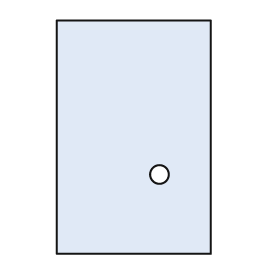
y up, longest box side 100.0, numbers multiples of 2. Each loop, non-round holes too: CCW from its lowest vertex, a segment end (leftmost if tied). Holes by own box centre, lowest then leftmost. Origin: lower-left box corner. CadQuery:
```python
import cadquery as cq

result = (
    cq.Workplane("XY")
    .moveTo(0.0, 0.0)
    .lineTo(66.0, 0.0)
    .lineTo(66.0, 100.0)
    .lineTo(0.0, 100.0)
    .close()
    .moveTo(44.0, 34.0)
    .circle(4.0)
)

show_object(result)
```